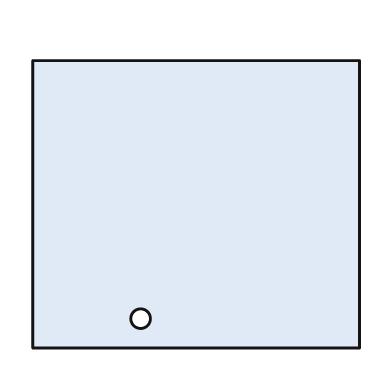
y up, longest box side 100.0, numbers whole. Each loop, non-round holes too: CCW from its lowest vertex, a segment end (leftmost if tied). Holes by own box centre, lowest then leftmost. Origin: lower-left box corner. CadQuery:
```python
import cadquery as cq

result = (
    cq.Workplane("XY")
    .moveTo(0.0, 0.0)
    .lineTo(100.0, 0.0)
    .lineTo(100.0, 88.0)
    .lineTo(0.0, 88.0)
    .close()
    .moveTo(33.0, 9.0)
    .circle(3.0)
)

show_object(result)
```